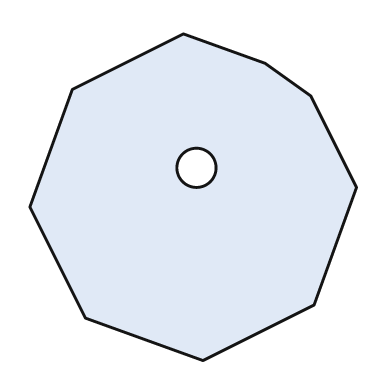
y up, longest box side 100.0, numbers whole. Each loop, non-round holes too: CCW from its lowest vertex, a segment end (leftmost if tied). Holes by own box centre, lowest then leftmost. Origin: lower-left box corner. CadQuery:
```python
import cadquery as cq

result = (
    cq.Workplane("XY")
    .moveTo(53.0, 0.0)
    .lineTo(87.0, 17.0)
    .lineTo(100.0, 53.0)
    .lineTo(86.0, 81.0)
    .lineTo(72.0, 91.0)
    .lineTo(47.0, 100.0)
    .lineTo(13.0, 83.0)
    .lineTo(0.0, 47.0)
    .lineTo(17.0, 13.0)
    .close()
    .moveTo(51.0, 59.0)
    .circle(6.0)
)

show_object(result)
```